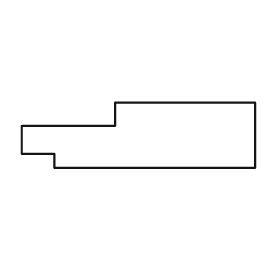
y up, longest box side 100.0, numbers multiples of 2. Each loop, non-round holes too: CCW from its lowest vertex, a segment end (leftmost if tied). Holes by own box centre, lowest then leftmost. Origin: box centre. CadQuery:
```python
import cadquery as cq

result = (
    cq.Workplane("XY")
    .moveTo(-36.0, -14.0)
    .lineTo(50.0, -14.0)
    .lineTo(50.0, 14.0)
    .lineTo(-10.0, 14.0)
    .lineTo(-10.0, 4.0)
    .lineTo(-50.0, 4.0)
    .lineTo(-50.0, -8.0)
    .lineTo(-36.0, -8.0)
    .close()
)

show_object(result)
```